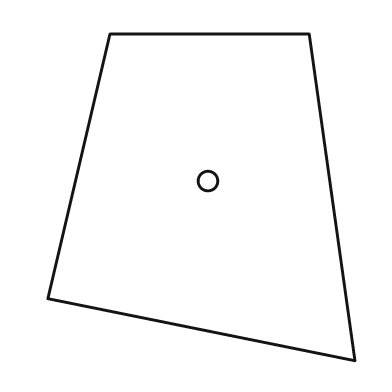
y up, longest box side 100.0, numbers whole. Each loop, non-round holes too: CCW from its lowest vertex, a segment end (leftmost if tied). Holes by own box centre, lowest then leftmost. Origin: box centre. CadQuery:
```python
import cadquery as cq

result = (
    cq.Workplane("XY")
    .moveTo(47.0, -50.0)
    .lineTo(33.0, 50.0)
    .lineTo(-28.0, 50.0)
    .lineTo(-47.0, -31.0)
    .close()
    .moveTo(2.0, 5.0)
    .circle(3.0)
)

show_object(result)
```